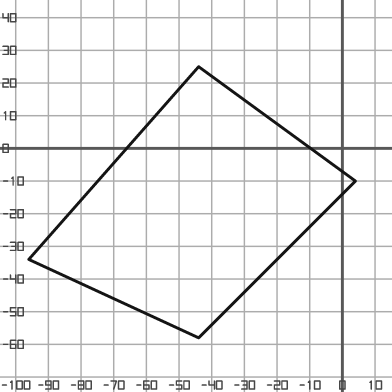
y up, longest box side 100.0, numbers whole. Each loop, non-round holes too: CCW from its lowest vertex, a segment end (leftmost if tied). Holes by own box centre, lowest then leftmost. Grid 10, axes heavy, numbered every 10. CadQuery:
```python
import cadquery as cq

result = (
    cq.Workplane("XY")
    .moveTo(-44.0, -58.0)
    .lineTo(4.0, -10.0)
    .lineTo(-44.0, 25.0)
    .lineTo(-96.0, -34.0)
    .close()
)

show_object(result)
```